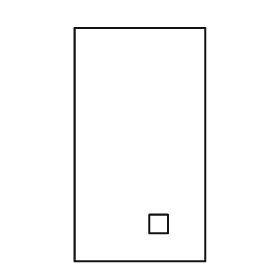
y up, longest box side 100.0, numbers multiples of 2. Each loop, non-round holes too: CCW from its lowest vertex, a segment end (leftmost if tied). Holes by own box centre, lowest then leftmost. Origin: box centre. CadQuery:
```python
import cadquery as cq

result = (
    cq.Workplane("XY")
    .moveTo(-28.0, -50.0)
    .lineTo(28.0, -50.0)
    .lineTo(28.0, 50.0)
    .lineTo(-28.0, 50.0)
    .close()
    .moveTo(4.0, -38.0)
    .lineTo(12.0, -38.0)
    .lineTo(12.0, -30.0)
    .lineTo(4.0, -30.0)
    .close()
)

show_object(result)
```